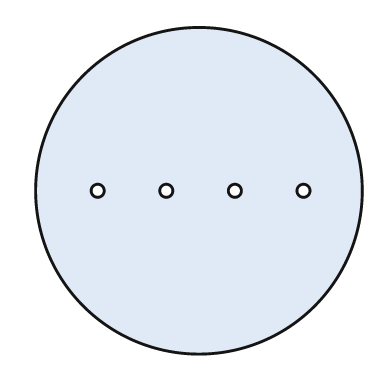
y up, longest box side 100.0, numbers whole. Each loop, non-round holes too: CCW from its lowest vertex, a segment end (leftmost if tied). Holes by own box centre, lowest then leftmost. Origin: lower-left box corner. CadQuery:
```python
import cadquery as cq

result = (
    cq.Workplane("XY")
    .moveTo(50.0, 50.0)
    .circle(50.0)
    .moveTo(19.0, 50.0)
    .circle(2.0)
    .moveTo(40.0, 50.0)
    .circle(2.0)
    .moveTo(61.0, 50.0)
    .circle(2.0)
    .moveTo(82.0, 50.0)
    .circle(2.0)
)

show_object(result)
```